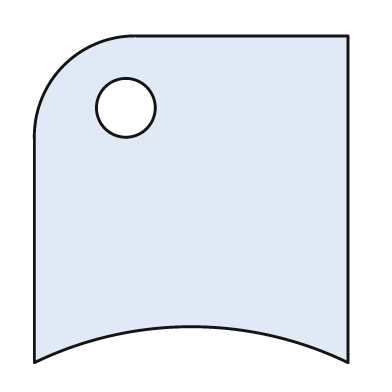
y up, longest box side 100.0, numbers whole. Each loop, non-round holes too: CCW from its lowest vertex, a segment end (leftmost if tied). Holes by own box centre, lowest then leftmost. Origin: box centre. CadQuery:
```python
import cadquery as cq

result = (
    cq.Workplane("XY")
    .moveTo(-48.0, -50.0)
    .threePointArc((0.0, -39.0), (48.0, -50.0))
    .lineTo(48.0, 50.0)
    .lineTo(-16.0, 50.0)
    .threePointArc((-39.0, 41.0), (-48.0, 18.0))
    .close()
    .moveTo(-20.0, 28.0)
    .circle(9.0)
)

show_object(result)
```